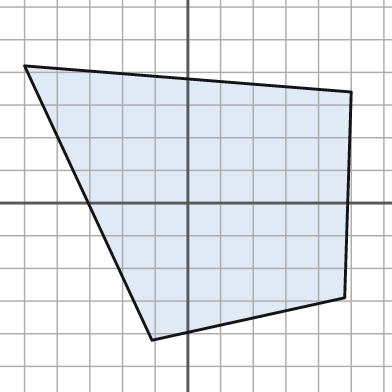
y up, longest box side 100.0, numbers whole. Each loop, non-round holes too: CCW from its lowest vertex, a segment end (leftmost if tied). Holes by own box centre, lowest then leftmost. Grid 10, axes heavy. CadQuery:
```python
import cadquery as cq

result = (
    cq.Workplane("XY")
    .moveTo(-11.0, -42.0)
    .lineTo(48.0, -29.0)
    .lineTo(50.0, 34.0)
    .lineTo(-50.0, 42.0)
    .close()
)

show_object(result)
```